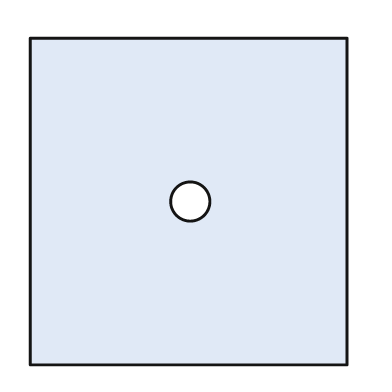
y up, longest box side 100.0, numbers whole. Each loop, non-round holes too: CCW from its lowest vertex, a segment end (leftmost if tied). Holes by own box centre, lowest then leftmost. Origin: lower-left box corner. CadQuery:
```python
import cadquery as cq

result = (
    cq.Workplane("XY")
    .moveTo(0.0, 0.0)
    .lineTo(97.0, 0.0)
    .lineTo(97.0, 100.0)
    .lineTo(0.0, 100.0)
    .close()
    .moveTo(49.0, 50.0)
    .circle(6.0)
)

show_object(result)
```